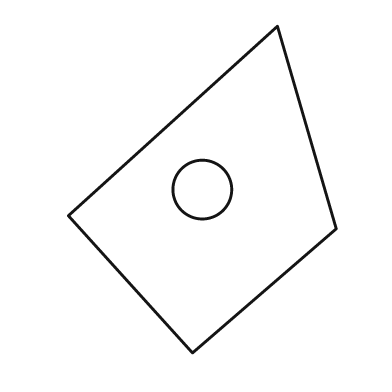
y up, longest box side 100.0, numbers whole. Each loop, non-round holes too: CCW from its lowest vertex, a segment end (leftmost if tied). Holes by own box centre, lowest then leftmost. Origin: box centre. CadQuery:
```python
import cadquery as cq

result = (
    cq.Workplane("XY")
    .moveTo(-3.0, -50.0)
    .lineTo(41.0, -12.0)
    .lineTo(23.0, 50.0)
    .lineTo(-41.0, -8.0)
    .close()
    .moveTo(0.0, 0.0)
    .circle(9.0)
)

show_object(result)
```